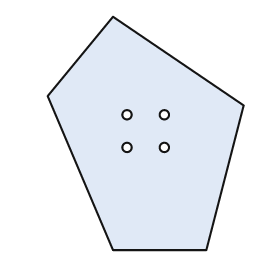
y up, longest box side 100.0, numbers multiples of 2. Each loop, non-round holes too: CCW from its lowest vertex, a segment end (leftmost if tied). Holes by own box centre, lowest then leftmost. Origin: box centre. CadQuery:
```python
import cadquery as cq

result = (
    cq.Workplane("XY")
    .moveTo(-14.0, -50.0)
    .lineTo(26.0, -50.0)
    .lineTo(42.0, 12.0)
    .lineTo(-14.0, 50.0)
    .lineTo(-42.0, 16.0)
    .close()
    .moveTo(-8.0, -6.0)
    .circle(2.0)
    .moveTo(8.0, -6.0)
    .circle(2.0)
    .moveTo(-8.0, 8.0)
    .circle(2.0)
    .moveTo(8.0, 8.0)
    .circle(2.0)
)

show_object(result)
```